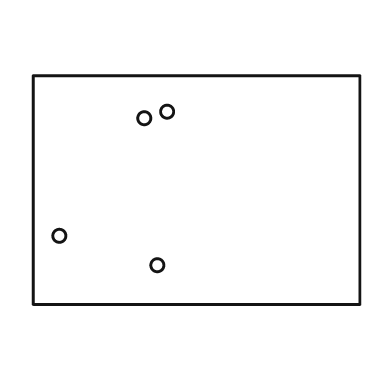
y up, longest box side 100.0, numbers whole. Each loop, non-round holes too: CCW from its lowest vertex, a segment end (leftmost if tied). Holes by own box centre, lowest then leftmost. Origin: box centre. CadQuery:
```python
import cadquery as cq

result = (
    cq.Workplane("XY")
    .moveTo(-50.0, -35.0)
    .lineTo(50.0, -35.0)
    .lineTo(50.0, 35.0)
    .lineTo(-50.0, 35.0)
    .close()
    .moveTo(-12.0, -23.0)
    .circle(2.0)
    .moveTo(-42.0, -14.0)
    .circle(2.0)
    .moveTo(-16.0, 22.0)
    .circle(2.0)
    .moveTo(-9.0, 24.0)
    .circle(2.0)
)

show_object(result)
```